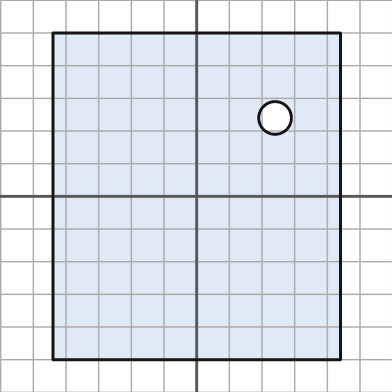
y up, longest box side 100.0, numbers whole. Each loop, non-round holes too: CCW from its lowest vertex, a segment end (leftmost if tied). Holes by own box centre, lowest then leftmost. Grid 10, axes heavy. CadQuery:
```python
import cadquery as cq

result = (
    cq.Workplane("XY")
    .moveTo(-44.0, -50.0)
    .lineTo(44.0, -50.0)
    .lineTo(44.0, 50.0)
    .lineTo(-44.0, 50.0)
    .close()
    .moveTo(24.0, 24.0)
    .circle(5.0)
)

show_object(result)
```